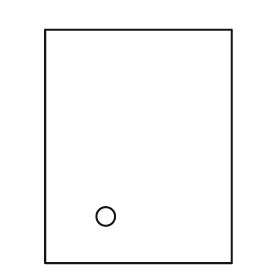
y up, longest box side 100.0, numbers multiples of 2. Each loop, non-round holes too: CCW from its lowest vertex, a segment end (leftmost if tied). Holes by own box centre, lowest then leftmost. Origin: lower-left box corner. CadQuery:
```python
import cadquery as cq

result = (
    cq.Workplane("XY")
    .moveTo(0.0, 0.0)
    .lineTo(80.0, 0.0)
    .lineTo(80.0, 100.0)
    .lineTo(0.0, 100.0)
    .close()
    .moveTo(26.0, 20.0)
    .circle(4.0)
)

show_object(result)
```